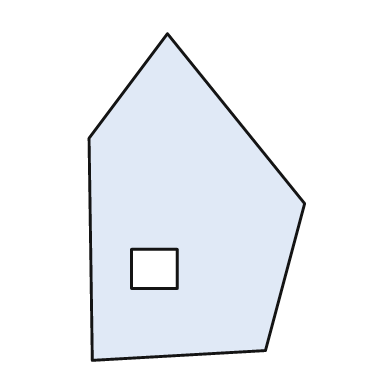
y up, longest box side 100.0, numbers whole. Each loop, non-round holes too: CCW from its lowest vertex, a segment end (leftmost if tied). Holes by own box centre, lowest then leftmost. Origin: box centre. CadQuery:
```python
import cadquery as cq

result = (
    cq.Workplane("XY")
    .moveTo(-32.0, -50.0)
    .lineTo(21.0, -47.0)
    .lineTo(33.0, -2.0)
    .lineTo(-9.0, 50.0)
    .lineTo(-33.0, 18.0)
    .close()
    .moveTo(-20.0, -28.0)
    .lineTo(-6.0, -28.0)
    .lineTo(-6.0, -16.0)
    .lineTo(-20.0, -16.0)
    .close()
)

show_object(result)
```